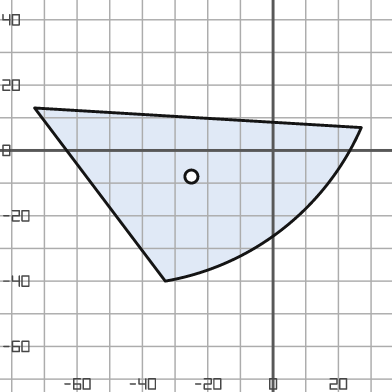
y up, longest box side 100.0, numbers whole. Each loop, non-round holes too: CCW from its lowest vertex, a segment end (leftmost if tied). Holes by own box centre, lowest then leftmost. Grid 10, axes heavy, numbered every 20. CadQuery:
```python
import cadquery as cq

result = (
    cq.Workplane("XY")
    .moveTo(-33.0, -40.0)
    .threePointArc((3.0, -24.0), (27.0, 7.0))
    .lineTo(-73.0, 13.0)
    .close()
    .moveTo(-25.0, -8.0)
    .circle(2.0)
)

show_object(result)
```